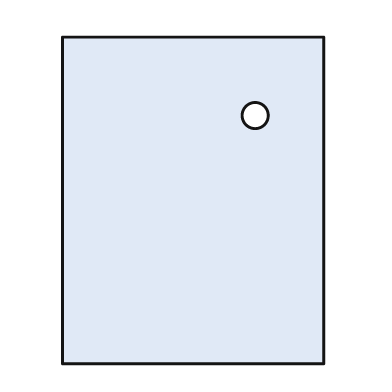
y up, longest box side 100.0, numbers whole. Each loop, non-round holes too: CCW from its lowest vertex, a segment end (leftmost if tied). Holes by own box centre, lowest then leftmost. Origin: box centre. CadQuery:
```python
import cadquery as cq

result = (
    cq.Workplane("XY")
    .moveTo(-40.0, -50.0)
    .lineTo(40.0, -50.0)
    .lineTo(40.0, 50.0)
    .lineTo(-40.0, 50.0)
    .close()
    .moveTo(19.0, 26.0)
    .circle(4.0)
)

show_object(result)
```